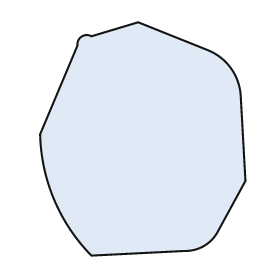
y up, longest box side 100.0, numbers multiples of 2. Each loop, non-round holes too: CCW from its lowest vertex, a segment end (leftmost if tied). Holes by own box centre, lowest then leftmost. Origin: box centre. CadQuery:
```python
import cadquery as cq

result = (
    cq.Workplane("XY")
    .moveTo(-22.0, -50.0)
    .lineTo(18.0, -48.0)
    .threePointArc((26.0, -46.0), (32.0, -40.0))
    .lineTo(44.0, -18.0)
    .lineTo(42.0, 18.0)
    .threePointArc((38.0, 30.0), (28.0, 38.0))
    .lineTo(-2.0, 50.0)
    .lineTo(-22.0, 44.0)
    .threePointArc((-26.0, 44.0), (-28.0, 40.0))
    .lineTo(-44.0, 2.0)
    .threePointArc((-38.0, -26.0), (-22.0, -50.0))
    .close()
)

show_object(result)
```